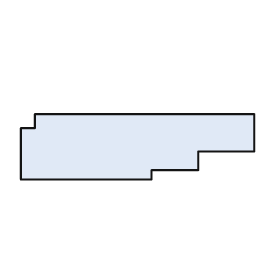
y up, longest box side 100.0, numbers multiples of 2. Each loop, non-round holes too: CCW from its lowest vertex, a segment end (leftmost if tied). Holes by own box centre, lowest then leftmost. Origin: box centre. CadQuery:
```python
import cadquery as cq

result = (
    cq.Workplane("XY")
    .moveTo(-50.0, -14.0)
    .lineTo(6.0, -14.0)
    .lineTo(6.0, -10.0)
    .lineTo(26.0, -10.0)
    .lineTo(26.0, -2.0)
    .lineTo(50.0, -2.0)
    .lineTo(50.0, 14.0)
    .lineTo(-44.0, 14.0)
    .lineTo(-44.0, 8.0)
    .lineTo(-50.0, 8.0)
    .close()
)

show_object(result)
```